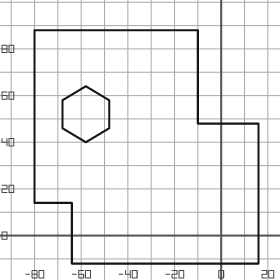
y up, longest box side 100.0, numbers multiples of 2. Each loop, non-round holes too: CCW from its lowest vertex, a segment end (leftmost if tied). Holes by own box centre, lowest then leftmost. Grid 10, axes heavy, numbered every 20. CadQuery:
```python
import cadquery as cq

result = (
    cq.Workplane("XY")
    .moveTo(-64.0, -12.0)
    .lineTo(16.0, -12.0)
    .lineTo(16.0, 48.0)
    .lineTo(-10.0, 48.0)
    .lineTo(-10.0, 88.0)
    .lineTo(-80.0, 88.0)
    .lineTo(-80.0, 14.0)
    .lineTo(-64.0, 14.0)
    .close()
    .moveTo(-58.0, 40.0)
    .lineTo(-48.0, 46.0)
    .lineTo(-48.0, 58.0)
    .lineTo(-58.0, 64.0)
    .lineTo(-68.0, 58.0)
    .lineTo(-68.0, 46.0)
    .close()
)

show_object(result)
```